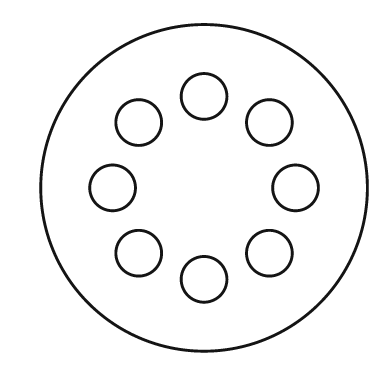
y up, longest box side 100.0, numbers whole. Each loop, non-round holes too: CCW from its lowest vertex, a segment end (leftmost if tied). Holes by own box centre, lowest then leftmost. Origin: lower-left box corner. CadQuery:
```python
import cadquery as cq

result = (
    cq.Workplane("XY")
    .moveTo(50.0, 50.0)
    .circle(50.0)
    .moveTo(50.0, 22.0)
    .circle(7.0)
    .moveTo(30.0, 30.0)
    .circle(7.0)
    .moveTo(70.0, 30.0)
    .circle(7.0)
    .moveTo(22.0, 50.0)
    .circle(7.0)
    .moveTo(78.0, 50.0)
    .circle(7.0)
    .moveTo(30.0, 70.0)
    .circle(7.0)
    .moveTo(70.0, 70.0)
    .circle(7.0)
    .moveTo(50.0, 78.0)
    .circle(7.0)
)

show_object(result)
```